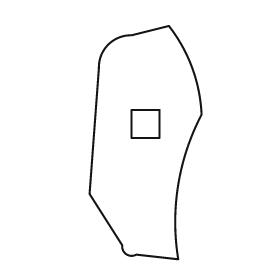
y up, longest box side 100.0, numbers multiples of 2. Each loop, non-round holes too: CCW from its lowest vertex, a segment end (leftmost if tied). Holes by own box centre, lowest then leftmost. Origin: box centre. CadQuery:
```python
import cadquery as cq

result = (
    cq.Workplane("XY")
    .moveTo(14.0, -50.0)
    .threePointArc((14.0, -18.0), (24.0, 12.0))
    .threePointArc((20.0, 32.0), (10.0, 50.0))
    .lineTo(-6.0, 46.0)
    .threePointArc((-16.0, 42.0), (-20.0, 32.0))
    .lineTo(-24.0, -22.0)
    .lineTo(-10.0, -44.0)
    .threePointArc((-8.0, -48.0), (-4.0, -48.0))
    .close()
    .moveTo(-6.0, 2.0)
    .lineTo(6.0, 2.0)
    .lineTo(6.0, 14.0)
    .lineTo(-6.0, 14.0)
    .close()
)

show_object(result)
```